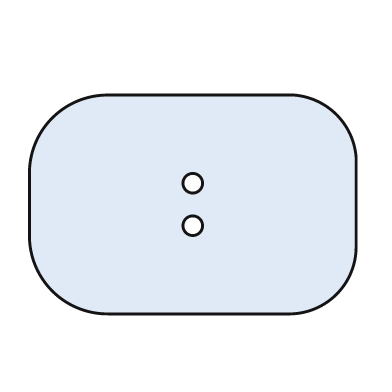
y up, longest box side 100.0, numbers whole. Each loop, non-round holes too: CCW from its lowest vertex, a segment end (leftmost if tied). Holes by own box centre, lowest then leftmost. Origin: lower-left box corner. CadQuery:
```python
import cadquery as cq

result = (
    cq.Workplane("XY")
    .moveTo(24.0, 0.0)
    .lineTo(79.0, 0.0)
    .threePointArc((94.0, 6.0), (100.0, 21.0))
    .lineTo(100.0, 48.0)
    .threePointArc((94.0, 61.0), (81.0, 67.0))
    .lineTo(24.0, 67.0)
    .threePointArc((7.0, 60.0), (0.0, 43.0))
    .lineTo(0.0, 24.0)
    .threePointArc((7.0, 7.0), (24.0, 0.0))
    .close()
    .moveTo(50.0, 27.0)
    .circle(3.0)
    .moveTo(50.0, 40.0)
    .circle(3.0)
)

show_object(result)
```